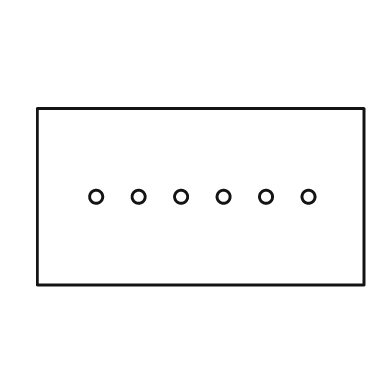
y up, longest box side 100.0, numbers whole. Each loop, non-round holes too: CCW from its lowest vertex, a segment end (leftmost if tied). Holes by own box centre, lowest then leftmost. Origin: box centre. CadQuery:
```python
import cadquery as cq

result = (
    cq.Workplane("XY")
    .moveTo(-50.0, -27.0)
    .lineTo(50.0, -27.0)
    .lineTo(50.0, 27.0)
    .lineTo(-50.0, 27.0)
    .close()
    .moveTo(-32.0, 0.0)
    .circle(2.0)
    .moveTo(-19.0, 0.0)
    .circle(2.0)
    .moveTo(-6.0, 0.0)
    .circle(2.0)
    .moveTo(7.0, 0.0)
    .circle(2.0)
    .moveTo(20.0, 0.0)
    .circle(2.0)
    .moveTo(33.0, 0.0)
    .circle(2.0)
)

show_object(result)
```